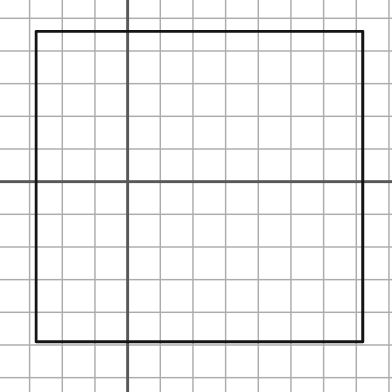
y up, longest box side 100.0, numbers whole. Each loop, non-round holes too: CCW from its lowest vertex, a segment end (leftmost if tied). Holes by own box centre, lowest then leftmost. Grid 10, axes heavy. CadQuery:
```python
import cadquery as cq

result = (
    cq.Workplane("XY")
    .moveTo(-28.0, -49.0)
    .lineTo(72.0, -49.0)
    .lineTo(72.0, 46.0)
    .lineTo(-28.0, 46.0)
    .close()
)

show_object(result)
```